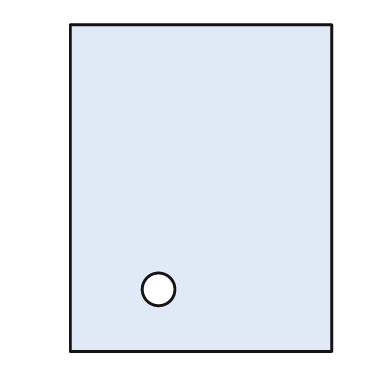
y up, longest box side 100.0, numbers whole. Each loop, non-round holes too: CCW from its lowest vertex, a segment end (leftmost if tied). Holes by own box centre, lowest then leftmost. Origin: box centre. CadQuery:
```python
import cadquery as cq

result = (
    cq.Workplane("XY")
    .moveTo(-40.0, -50.0)
    .lineTo(40.0, -50.0)
    .lineTo(40.0, 50.0)
    .lineTo(-40.0, 50.0)
    .close()
    .moveTo(-13.0, -31.0)
    .circle(5.0)
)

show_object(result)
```